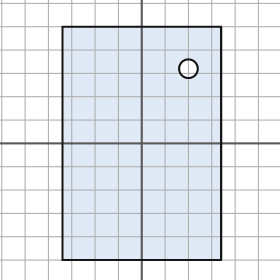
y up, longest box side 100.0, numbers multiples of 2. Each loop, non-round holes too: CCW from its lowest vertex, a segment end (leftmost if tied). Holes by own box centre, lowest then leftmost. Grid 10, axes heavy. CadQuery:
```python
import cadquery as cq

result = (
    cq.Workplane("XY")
    .moveTo(-34.0, -50.0)
    .lineTo(34.0, -50.0)
    .lineTo(34.0, 50.0)
    .lineTo(-34.0, 50.0)
    .close()
    .moveTo(20.0, 32.0)
    .circle(4.0)
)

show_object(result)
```